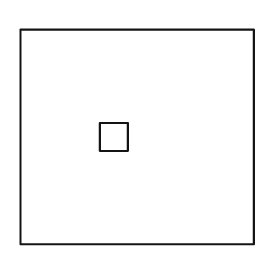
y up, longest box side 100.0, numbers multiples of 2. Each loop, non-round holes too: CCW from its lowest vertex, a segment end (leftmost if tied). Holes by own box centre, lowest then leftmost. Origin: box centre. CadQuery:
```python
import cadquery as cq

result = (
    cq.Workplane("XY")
    .moveTo(-50.0, -46.0)
    .lineTo(50.0, -46.0)
    .lineTo(50.0, 46.0)
    .lineTo(-50.0, 46.0)
    .close()
    .moveTo(-16.0, -6.0)
    .lineTo(-4.0, -6.0)
    .lineTo(-4.0, 6.0)
    .lineTo(-16.0, 6.0)
    .close()
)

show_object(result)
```